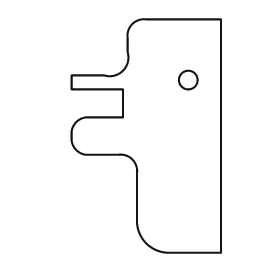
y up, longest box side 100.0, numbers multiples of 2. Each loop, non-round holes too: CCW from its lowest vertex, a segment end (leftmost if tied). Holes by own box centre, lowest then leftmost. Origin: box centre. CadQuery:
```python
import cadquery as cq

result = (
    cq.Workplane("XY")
    .moveTo(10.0, -50.0)
    .lineTo(32.0, -50.0)
    .lineTo(32.0, 50.0)
    .lineTo(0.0, 50.0)
    .threePointArc((-6.0, 48.0), (-8.0, 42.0))
    .lineTo(-8.0, 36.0)
    .threePointArc((-10.0, 28.0), (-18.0, 26.0))
    .lineTo(-32.0, 26.0)
    .lineTo(-32.0, 20.0)
    .lineTo(-10.0, 20.0)
    .lineTo(-10.0, 8.0)
    .lineTo(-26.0, 8.0)
    .threePointArc((-30.0, 6.0), (-32.0, 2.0))
    .lineTo(-32.0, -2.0)
    .threePointArc((-30.0, -6.0), (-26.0, -8.0))
    .lineTo(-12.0, -8.0)
    .threePointArc((-6.0, -10.0), (-4.0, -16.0))
    .lineTo(-4.0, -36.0)
    .threePointArc((0.0, -46.0), (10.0, -50.0))
    .close()
    .moveTo(18.0, 24.0)
    .circle(4.0)
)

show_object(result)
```